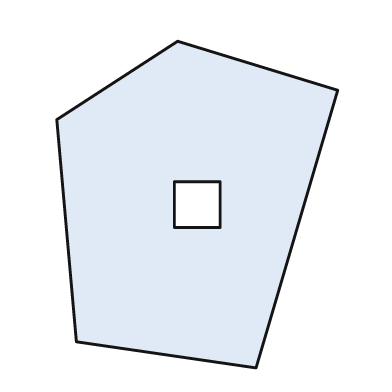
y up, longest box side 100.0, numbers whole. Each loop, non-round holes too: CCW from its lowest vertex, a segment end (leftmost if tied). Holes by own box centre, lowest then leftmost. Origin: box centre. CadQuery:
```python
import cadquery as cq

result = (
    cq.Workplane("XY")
    .moveTo(18.0, -50.0)
    .lineTo(43.0, 35.0)
    .lineTo(-6.0, 50.0)
    .lineTo(-43.0, 26.0)
    .lineTo(-37.0, -42.0)
    .close()
    .moveTo(-7.0, -7.0)
    .lineTo(7.0, -7.0)
    .lineTo(7.0, 7.0)
    .lineTo(-7.0, 7.0)
    .close()
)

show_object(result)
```